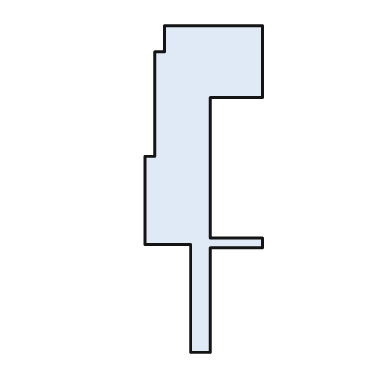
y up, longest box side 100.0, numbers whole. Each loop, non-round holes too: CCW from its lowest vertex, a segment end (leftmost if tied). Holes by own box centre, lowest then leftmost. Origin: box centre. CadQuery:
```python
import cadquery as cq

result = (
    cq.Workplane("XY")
    .moveTo(-4.0, -50.0)
    .lineTo(2.0, -50.0)
    .lineTo(2.0, -18.0)
    .lineTo(18.0, -18.0)
    .lineTo(18.0, -15.0)
    .lineTo(2.0, -15.0)
    .lineTo(2.0, 28.0)
    .lineTo(18.0, 28.0)
    .lineTo(18.0, 50.0)
    .lineTo(-12.0, 50.0)
    .lineTo(-12.0, 42.0)
    .lineTo(-15.0, 42.0)
    .lineTo(-15.0, 10.0)
    .lineTo(-18.0, 10.0)
    .lineTo(-18.0, -17.0)
    .lineTo(-4.0, -17.0)
    .close()
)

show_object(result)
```